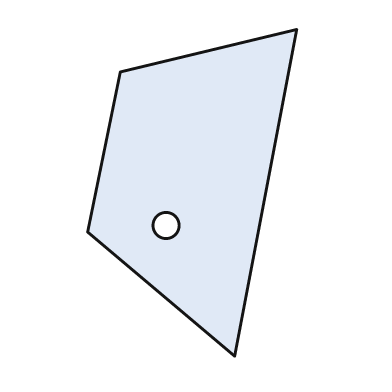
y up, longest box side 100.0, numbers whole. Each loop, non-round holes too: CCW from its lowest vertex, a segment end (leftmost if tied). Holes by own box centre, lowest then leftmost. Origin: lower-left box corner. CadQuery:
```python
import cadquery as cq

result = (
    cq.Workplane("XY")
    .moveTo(45.0, 0.0)
    .lineTo(64.0, 100.0)
    .lineTo(10.0, 87.0)
    .lineTo(0.0, 38.0)
    .close()
    .moveTo(24.0, 40.0)
    .circle(4.0)
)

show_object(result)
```